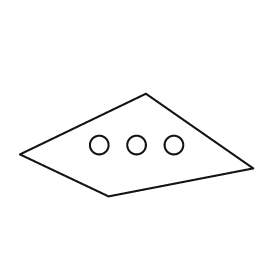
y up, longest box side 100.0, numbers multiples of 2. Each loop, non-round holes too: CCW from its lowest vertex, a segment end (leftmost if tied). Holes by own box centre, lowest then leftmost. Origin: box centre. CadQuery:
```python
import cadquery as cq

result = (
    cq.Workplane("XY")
    .moveTo(-12.0, -22.0)
    .lineTo(50.0, -10.0)
    .lineTo(4.0, 22.0)
    .lineTo(-50.0, -4.0)
    .close()
    .moveTo(-16.0, 0.0)
    .circle(4.0)
    .moveTo(0.0, 0.0)
    .circle(4.0)
    .moveTo(16.0, 0.0)
    .circle(4.0)
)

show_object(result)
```